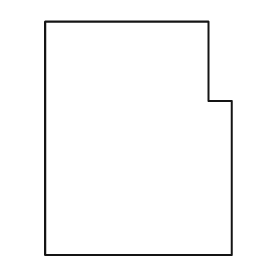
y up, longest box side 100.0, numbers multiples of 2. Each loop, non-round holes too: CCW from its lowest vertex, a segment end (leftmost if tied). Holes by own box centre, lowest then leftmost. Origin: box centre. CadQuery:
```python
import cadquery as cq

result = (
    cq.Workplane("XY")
    .moveTo(-40.0, -50.0)
    .lineTo(40.0, -50.0)
    .lineTo(40.0, 16.0)
    .lineTo(30.0, 16.0)
    .lineTo(30.0, 50.0)
    .lineTo(-40.0, 50.0)
    .close()
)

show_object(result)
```